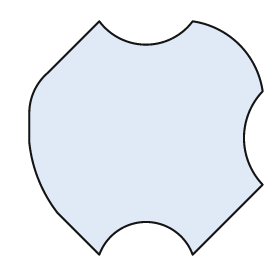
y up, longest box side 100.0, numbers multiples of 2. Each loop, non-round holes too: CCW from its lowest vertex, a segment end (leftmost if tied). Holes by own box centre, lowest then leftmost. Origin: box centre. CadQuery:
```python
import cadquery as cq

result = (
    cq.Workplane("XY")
    .moveTo(-20.0, -50.0)
    .threePointArc((0.0, -36.0), (20.0, -50.0))
    .lineTo(50.0, -20.0)
    .threePointArc((42.0, 0.0), (50.0, 20.0))
    .threePointArc((40.0, 40.0), (20.0, 50.0))
    .threePointArc((0.0, 40.0), (-20.0, 50.0))
    .lineTo(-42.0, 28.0)
    .threePointArc((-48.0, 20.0), (-50.0, 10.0))
    .lineTo(-50.0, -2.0)
    .threePointArc((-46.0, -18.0), (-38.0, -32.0))
    .close()
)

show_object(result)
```